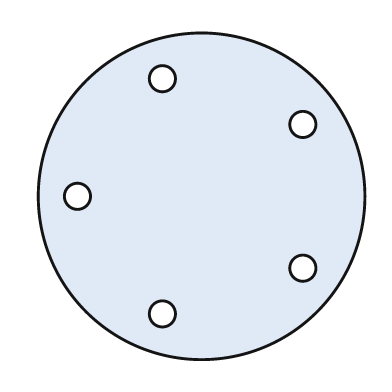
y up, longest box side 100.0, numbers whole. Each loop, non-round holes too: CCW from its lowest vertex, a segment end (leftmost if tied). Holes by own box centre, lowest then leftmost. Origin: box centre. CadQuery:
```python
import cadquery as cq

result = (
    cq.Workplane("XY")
    .moveTo(0.0, 0.0)
    .circle(50.0)
    .moveTo(-12.0, -36.0)
    .circle(4.0)
    .moveTo(31.0, -22.0)
    .circle(4.0)
    .moveTo(-38.0, 0.0)
    .circle(4.0)
    .moveTo(31.0, 22.0)
    .circle(4.0)
    .moveTo(-12.0, 36.0)
    .circle(4.0)
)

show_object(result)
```